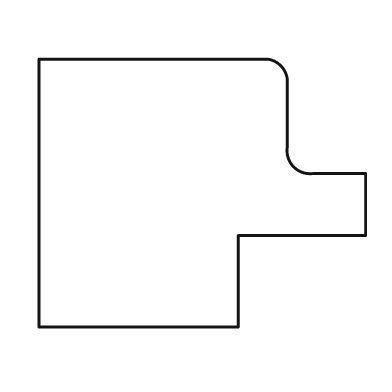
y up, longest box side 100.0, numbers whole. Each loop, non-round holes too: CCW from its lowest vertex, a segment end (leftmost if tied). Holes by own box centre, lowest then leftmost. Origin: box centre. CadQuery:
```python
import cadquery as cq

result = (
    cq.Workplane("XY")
    .moveTo(-50.0, -41.0)
    .lineTo(11.0, -41.0)
    .lineTo(11.0, -13.0)
    .lineTo(50.0, -13.0)
    .lineTo(50.0, 6.0)
    .lineTo(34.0, 6.0)
    .threePointArc((28.0, 8.0), (26.0, 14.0))
    .lineTo(26.0, 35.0)
    .threePointArc((24.0, 39.0), (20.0, 41.0))
    .lineTo(-50.0, 41.0)
    .close()
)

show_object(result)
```